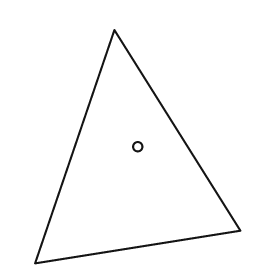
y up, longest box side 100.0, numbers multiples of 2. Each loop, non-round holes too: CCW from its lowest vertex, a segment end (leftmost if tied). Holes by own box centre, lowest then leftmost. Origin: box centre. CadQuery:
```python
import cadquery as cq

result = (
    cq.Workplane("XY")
    .moveTo(-44.0, -50.0)
    .lineTo(44.0, -36.0)
    .lineTo(-10.0, 50.0)
    .close()
    .moveTo(0.0, 0.0)
    .circle(2.0)
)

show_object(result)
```